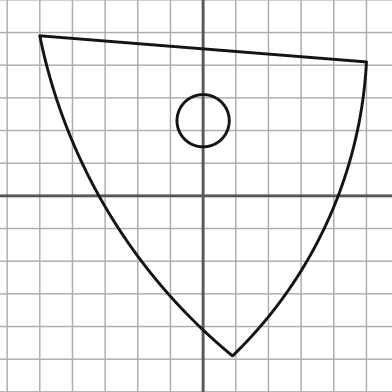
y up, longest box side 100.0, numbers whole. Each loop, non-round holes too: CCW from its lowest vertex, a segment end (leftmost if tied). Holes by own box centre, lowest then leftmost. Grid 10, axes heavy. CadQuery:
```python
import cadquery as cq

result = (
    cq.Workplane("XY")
    .moveTo(9.0, -49.0)
    .threePointArc((38.0, -8.0), (50.0, 41.0))
    .lineTo(-50.0, 49.0)
    .threePointArc((-29.0, -5.0), (9.0, -49.0))
    .close()
    .moveTo(0.0, 23.0)
    .circle(8.0)
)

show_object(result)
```